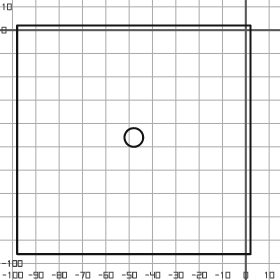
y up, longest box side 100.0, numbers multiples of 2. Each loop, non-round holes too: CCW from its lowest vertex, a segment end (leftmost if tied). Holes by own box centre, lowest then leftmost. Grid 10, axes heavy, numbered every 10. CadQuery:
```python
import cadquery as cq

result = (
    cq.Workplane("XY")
    .moveTo(-98.0, -96.0)
    .lineTo(2.0, -96.0)
    .lineTo(2.0, 2.0)
    .lineTo(-98.0, 2.0)
    .close()
    .moveTo(-48.0, -46.0)
    .circle(4.0)
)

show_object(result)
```